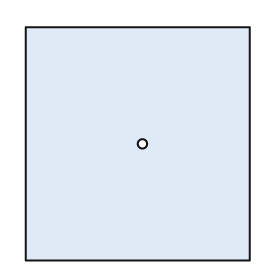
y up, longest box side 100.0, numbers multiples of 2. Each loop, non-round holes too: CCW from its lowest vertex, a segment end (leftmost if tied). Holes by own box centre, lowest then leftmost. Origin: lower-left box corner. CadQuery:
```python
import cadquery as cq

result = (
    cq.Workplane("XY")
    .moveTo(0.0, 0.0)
    .lineTo(96.0, 0.0)
    .lineTo(96.0, 100.0)
    .lineTo(0.0, 100.0)
    .close()
    .moveTo(50.0, 50.0)
    .circle(2.0)
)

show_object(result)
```